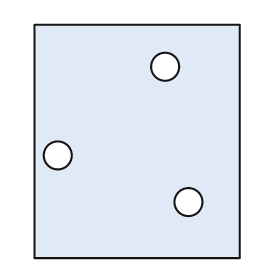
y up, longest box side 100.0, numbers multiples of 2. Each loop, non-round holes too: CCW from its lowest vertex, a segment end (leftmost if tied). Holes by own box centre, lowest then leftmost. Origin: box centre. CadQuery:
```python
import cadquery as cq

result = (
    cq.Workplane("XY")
    .moveTo(-44.0, -50.0)
    .lineTo(44.0, -50.0)
    .lineTo(44.0, 50.0)
    .lineTo(-44.0, 50.0)
    .close()
    .moveTo(22.0, -26.0)
    .circle(6.0)
    .moveTo(-34.0, -6.0)
    .circle(6.0)
    .moveTo(12.0, 32.0)
    .circle(6.0)
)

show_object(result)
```